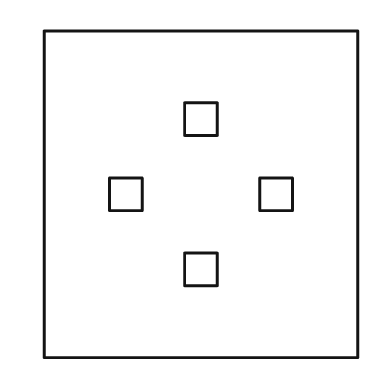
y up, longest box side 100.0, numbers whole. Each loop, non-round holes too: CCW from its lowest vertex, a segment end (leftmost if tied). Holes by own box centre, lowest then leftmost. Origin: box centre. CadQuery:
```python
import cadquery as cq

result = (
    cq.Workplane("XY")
    .moveTo(-48.0, -50.0)
    .lineTo(48.0, -50.0)
    .lineTo(48.0, 50.0)
    .lineTo(-48.0, 50.0)
    .close()
    .moveTo(-5.0, -28.0)
    .lineTo(5.0, -28.0)
    .lineTo(5.0, -18.0)
    .lineTo(-5.0, -18.0)
    .close()
    .moveTo(-28.0, -5.0)
    .lineTo(-18.0, -5.0)
    .lineTo(-18.0, 5.0)
    .lineTo(-28.0, 5.0)
    .close()
    .moveTo(18.0, -5.0)
    .lineTo(28.0, -5.0)
    .lineTo(28.0, 5.0)
    .lineTo(18.0, 5.0)
    .close()
    .moveTo(-5.0, 18.0)
    .lineTo(5.0, 18.0)
    .lineTo(5.0, 28.0)
    .lineTo(-5.0, 28.0)
    .close()
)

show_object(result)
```